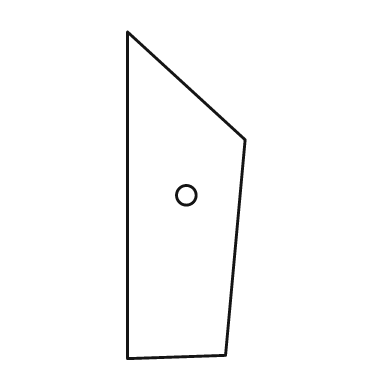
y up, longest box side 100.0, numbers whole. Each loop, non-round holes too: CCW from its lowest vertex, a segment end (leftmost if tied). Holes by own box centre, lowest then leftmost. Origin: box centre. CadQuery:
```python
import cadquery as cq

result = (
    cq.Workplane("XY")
    .moveTo(-18.0, -50.0)
    .lineTo(12.0, -49.0)
    .lineTo(18.0, 17.0)
    .lineTo(-18.0, 50.0)
    .close()
    .moveTo(0.0, 0.0)
    .circle(3.0)
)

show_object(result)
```